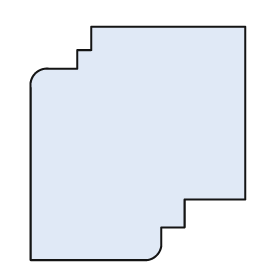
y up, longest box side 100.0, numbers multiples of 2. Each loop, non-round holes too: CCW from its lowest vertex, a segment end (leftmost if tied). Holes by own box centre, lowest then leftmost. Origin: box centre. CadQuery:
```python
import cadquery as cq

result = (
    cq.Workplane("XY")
    .moveTo(-46.0, -50.0)
    .lineTo(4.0, -50.0)
    .threePointArc((8.0, -48.0), (10.0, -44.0))
    .lineTo(10.0, -36.0)
    .lineTo(20.0, -36.0)
    .lineTo(20.0, -24.0)
    .lineTo(46.0, -24.0)
    .lineTo(46.0, 50.0)
    .lineTo(-20.0, 50.0)
    .lineTo(-20.0, 40.0)
    .lineTo(-26.0, 40.0)
    .lineTo(-26.0, 32.0)
    .lineTo(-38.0, 32.0)
    .threePointArc((-44.0, 30.0), (-46.0, 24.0))
    .close()
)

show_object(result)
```